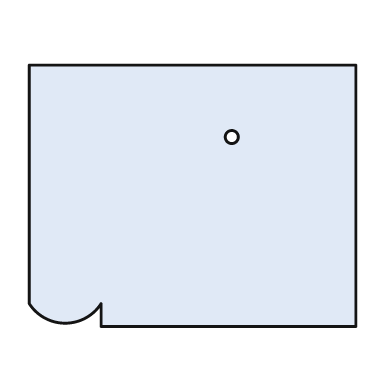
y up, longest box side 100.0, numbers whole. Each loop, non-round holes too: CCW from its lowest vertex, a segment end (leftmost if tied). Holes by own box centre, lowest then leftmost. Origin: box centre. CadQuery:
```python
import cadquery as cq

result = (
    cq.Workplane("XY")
    .moveTo(-28.0, -40.0)
    .lineTo(50.0, -40.0)
    .lineTo(50.0, 40.0)
    .lineTo(-50.0, 40.0)
    .lineTo(-50.0, -33.0)
    .threePointArc((-39.0, -39.0), (-28.0, -33.0))
    .close()
    .moveTo(12.0, 18.0)
    .circle(2.0)
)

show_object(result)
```